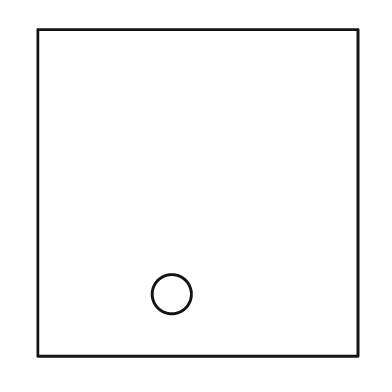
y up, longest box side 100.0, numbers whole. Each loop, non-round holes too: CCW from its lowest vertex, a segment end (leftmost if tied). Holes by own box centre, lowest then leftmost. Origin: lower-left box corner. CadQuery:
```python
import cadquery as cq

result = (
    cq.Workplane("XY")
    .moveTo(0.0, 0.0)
    .lineTo(98.0, 0.0)
    .lineTo(98.0, 100.0)
    .lineTo(0.0, 100.0)
    .close()
    .moveTo(41.0, 19.0)
    .circle(6.0)
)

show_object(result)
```